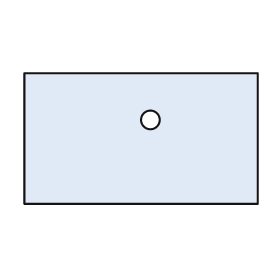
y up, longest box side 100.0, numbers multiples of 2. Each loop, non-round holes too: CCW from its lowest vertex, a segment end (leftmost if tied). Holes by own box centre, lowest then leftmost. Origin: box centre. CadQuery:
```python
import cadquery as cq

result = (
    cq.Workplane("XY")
    .moveTo(-50.0, -28.0)
    .lineTo(50.0, -28.0)
    .lineTo(50.0, 28.0)
    .lineTo(-50.0, 28.0)
    .close()
    .moveTo(4.0, 8.0)
    .circle(4.0)
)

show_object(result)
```